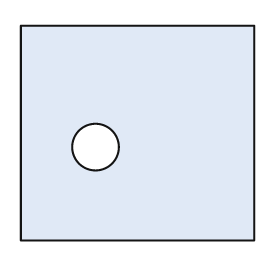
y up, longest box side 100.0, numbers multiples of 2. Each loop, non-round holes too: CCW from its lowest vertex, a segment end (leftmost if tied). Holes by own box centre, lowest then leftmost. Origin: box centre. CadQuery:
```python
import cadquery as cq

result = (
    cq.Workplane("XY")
    .moveTo(-50.0, -46.0)
    .lineTo(50.0, -46.0)
    .lineTo(50.0, 46.0)
    .lineTo(-50.0, 46.0)
    .close()
    .moveTo(-18.0, -6.0)
    .circle(10.0)
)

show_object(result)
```